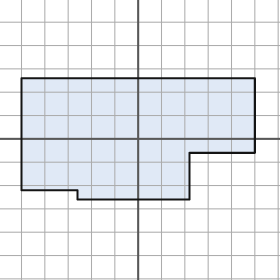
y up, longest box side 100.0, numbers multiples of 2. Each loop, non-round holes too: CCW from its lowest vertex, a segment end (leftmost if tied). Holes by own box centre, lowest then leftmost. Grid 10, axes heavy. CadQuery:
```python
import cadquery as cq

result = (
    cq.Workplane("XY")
    .moveTo(-26.0, -26.0)
    .lineTo(22.0, -26.0)
    .lineTo(22.0, -6.0)
    .lineTo(50.0, -6.0)
    .lineTo(50.0, 26.0)
    .lineTo(-50.0, 26.0)
    .lineTo(-50.0, -22.0)
    .lineTo(-26.0, -22.0)
    .close()
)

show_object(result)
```